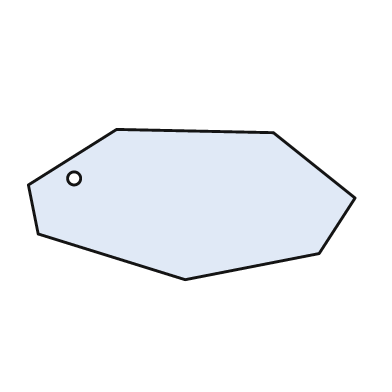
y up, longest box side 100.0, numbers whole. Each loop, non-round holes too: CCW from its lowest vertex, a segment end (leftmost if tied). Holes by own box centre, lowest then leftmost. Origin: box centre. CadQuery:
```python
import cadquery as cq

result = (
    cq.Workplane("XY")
    .moveTo(-2.0, -23.0)
    .lineTo(39.0, -15.0)
    .lineTo(50.0, 2.0)
    .lineTo(25.0, 22.0)
    .lineTo(-23.0, 23.0)
    .lineTo(-50.0, 6.0)
    .lineTo(-47.0, -9.0)
    .close()
    .moveTo(-36.0, 8.0)
    .circle(2.0)
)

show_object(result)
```